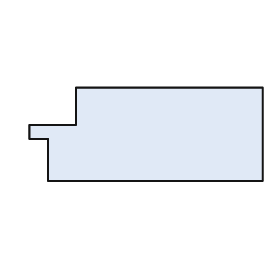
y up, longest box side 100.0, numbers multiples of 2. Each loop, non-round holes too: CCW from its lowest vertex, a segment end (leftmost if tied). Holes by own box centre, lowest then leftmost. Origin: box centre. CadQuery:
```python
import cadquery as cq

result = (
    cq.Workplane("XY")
    .moveTo(-42.0, -20.0)
    .lineTo(50.0, -20.0)
    .lineTo(50.0, 20.0)
    .lineTo(-30.0, 20.0)
    .lineTo(-30.0, 4.0)
    .lineTo(-50.0, 4.0)
    .lineTo(-50.0, -2.0)
    .lineTo(-42.0, -2.0)
    .close()
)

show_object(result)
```